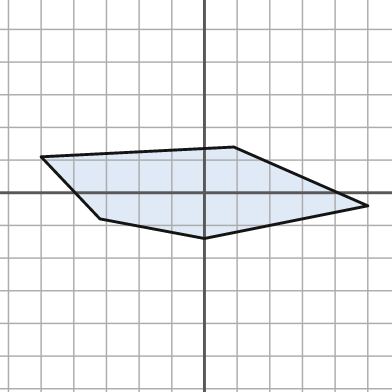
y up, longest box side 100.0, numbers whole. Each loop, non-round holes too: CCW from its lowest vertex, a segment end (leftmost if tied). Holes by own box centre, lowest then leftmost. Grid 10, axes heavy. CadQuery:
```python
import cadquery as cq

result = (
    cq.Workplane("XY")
    .moveTo(0.0, -14.0)
    .lineTo(50.0, -4.0)
    .lineTo(9.0, 14.0)
    .lineTo(-50.0, 11.0)
    .lineTo(-32.0, -8.0)
    .close()
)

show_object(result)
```